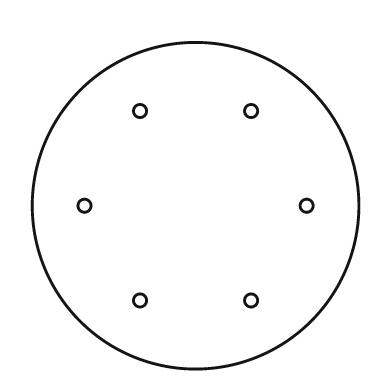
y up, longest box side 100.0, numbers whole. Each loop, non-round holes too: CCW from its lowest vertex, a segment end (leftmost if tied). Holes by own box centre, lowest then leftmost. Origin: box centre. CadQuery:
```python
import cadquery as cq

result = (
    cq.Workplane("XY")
    .moveTo(0.0, 0.0)
    .circle(50.0)
    .moveTo(-17.0, -29.0)
    .circle(2.0)
    .moveTo(17.0, -29.0)
    .circle(2.0)
    .moveTo(-34.0, 0.0)
    .circle(2.0)
    .moveTo(34.0, 0.0)
    .circle(2.0)
    .moveTo(-17.0, 29.0)
    .circle(2.0)
    .moveTo(17.0, 29.0)
    .circle(2.0)
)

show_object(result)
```